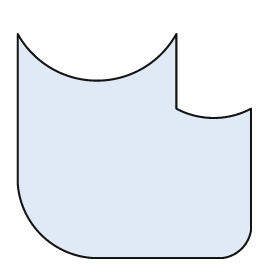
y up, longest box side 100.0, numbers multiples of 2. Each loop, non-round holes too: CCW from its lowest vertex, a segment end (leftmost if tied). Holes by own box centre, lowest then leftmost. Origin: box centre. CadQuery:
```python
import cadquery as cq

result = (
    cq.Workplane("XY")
    .moveTo(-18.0, -48.0)
    .lineTo(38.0, -48.0)
    .threePointArc((46.0, -44.0), (50.0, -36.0))
    .lineTo(50.0, 16.0)
    .threePointArc((34.0, 12.0), (18.0, 16.0))
    .lineTo(18.0, 48.0)
    .threePointArc((-16.0, 28.0), (-50.0, 48.0))
    .lineTo(-50.0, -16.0)
    .threePointArc((-40.0, -38.0), (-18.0, -48.0))
    .close()
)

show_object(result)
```